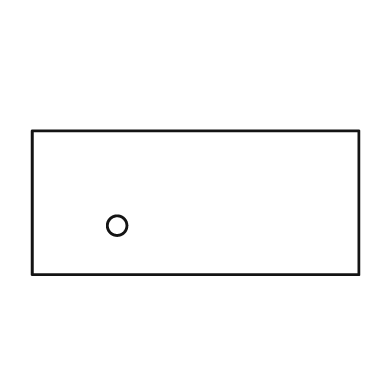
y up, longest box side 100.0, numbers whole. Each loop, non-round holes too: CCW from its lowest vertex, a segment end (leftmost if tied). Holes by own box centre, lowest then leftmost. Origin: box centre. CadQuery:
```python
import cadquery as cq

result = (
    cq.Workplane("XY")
    .moveTo(-50.0, -22.0)
    .lineTo(50.0, -22.0)
    .lineTo(50.0, 22.0)
    .lineTo(-50.0, 22.0)
    .close()
    .moveTo(-24.0, -7.0)
    .circle(3.0)
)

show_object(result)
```